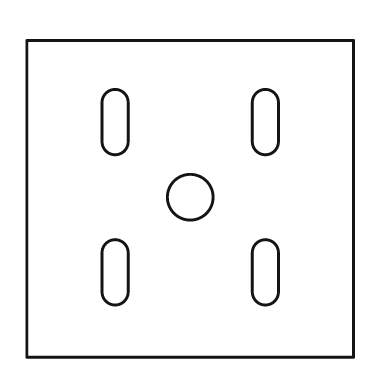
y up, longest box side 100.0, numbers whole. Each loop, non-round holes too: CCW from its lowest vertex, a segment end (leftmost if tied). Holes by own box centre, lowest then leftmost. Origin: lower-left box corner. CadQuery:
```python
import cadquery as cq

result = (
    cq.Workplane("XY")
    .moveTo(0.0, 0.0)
    .lineTo(100.0, 0.0)
    .lineTo(100.0, 97.0)
    .lineTo(0.0, 97.0)
    .close()
    .moveTo(23.0, 20.0)
    .threePointArc((27.0, 16.0), (31.0, 20.0))
    .lineTo(31.0, 32.0)
    .threePointArc((27.0, 36.0), (23.0, 32.0))
    .close()
    .moveTo(69.0, 20.0)
    .threePointArc((73.0, 16.0), (77.0, 20.0))
    .lineTo(77.0, 32.0)
    .threePointArc((73.0, 36.0), (69.0, 32.0))
    .close()
    .moveTo(50.0, 49.0)
    .circle(7.0)
    .moveTo(23.0, 66.0)
    .threePointArc((27.0, 62.0), (31.0, 66.0))
    .lineTo(31.0, 78.0)
    .threePointArc((27.0, 82.0), (23.0, 78.0))
    .close()
    .moveTo(69.0, 66.0)
    .threePointArc((73.0, 62.0), (77.0, 66.0))
    .lineTo(77.0, 78.0)
    .threePointArc((73.0, 82.0), (69.0, 78.0))
    .close()
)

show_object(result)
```